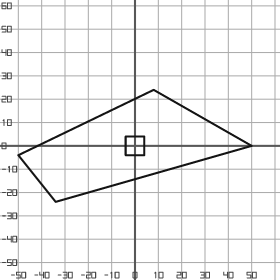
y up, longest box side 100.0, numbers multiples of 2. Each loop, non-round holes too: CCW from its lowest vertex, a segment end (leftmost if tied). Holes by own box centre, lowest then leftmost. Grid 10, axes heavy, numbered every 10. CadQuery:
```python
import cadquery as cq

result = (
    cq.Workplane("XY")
    .moveTo(-34.0, -24.0)
    .lineTo(50.0, 0.0)
    .lineTo(8.0, 24.0)
    .lineTo(-50.0, -4.0)
    .close()
    .moveTo(-4.0, -4.0)
    .lineTo(4.0, -4.0)
    .lineTo(4.0, 4.0)
    .lineTo(-4.0, 4.0)
    .close()
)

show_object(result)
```